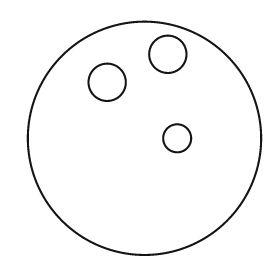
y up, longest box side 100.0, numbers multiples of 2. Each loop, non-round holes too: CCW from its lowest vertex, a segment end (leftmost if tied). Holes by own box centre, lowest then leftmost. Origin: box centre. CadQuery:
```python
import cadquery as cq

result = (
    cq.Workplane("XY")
    .moveTo(0.0, 0.0)
    .circle(50.0)
    .moveTo(14.0, 0.0)
    .circle(6.0)
    .moveTo(-16.0, 24.0)
    .circle(8.0)
    .moveTo(10.0, 36.0)
    .circle(8.0)
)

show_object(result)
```